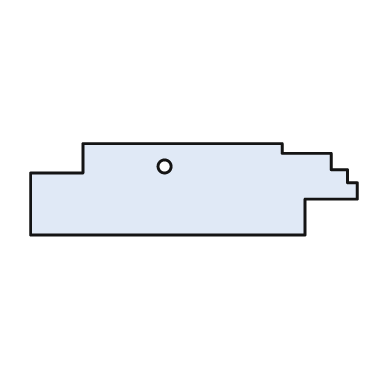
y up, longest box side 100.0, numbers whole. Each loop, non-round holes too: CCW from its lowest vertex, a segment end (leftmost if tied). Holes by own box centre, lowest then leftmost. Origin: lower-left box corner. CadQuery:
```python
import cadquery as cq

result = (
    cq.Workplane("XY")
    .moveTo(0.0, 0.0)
    .lineTo(84.0, 0.0)
    .lineTo(84.0, 11.0)
    .lineTo(100.0, 11.0)
    .lineTo(100.0, 16.0)
    .lineTo(97.0, 16.0)
    .lineTo(97.0, 20.0)
    .lineTo(92.0, 20.0)
    .lineTo(92.0, 25.0)
    .lineTo(77.0, 25.0)
    .lineTo(77.0, 28.0)
    .lineTo(16.0, 28.0)
    .lineTo(16.0, 19.0)
    .lineTo(0.0, 19.0)
    .close()
    .moveTo(41.0, 21.0)
    .circle(2.0)
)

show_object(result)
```